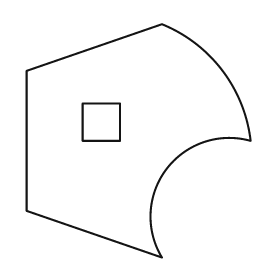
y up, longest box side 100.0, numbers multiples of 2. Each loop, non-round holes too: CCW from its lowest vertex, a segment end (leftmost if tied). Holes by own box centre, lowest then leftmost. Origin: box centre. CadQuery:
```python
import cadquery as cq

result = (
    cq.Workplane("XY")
    .moveTo(10.0, -50.0)
    .threePointArc((12.0, -12.0), (48.0, 0.0))
    .threePointArc((36.0, 30.0), (10.0, 50.0))
    .lineTo(-48.0, 30.0)
    .lineTo(-48.0, -30.0)
    .close()
    .moveTo(-24.0, 0.0)
    .lineTo(-8.0, 0.0)
    .lineTo(-8.0, 16.0)
    .lineTo(-24.0, 16.0)
    .close()
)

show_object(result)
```